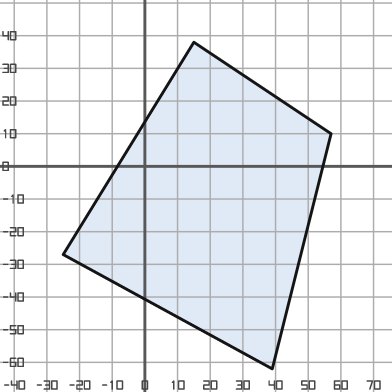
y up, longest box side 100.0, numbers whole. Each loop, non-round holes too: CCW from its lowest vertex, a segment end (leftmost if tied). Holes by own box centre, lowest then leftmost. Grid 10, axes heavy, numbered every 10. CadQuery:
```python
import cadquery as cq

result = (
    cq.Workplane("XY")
    .moveTo(39.0, -62.0)
    .lineTo(57.0, 10.0)
    .lineTo(15.0, 38.0)
    .lineTo(-25.0, -27.0)
    .close()
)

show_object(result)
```